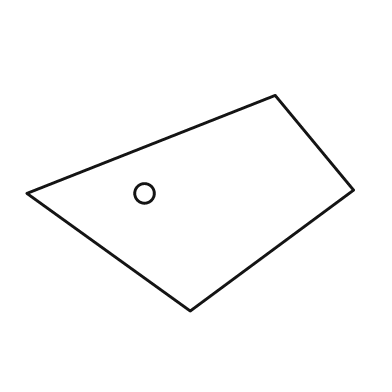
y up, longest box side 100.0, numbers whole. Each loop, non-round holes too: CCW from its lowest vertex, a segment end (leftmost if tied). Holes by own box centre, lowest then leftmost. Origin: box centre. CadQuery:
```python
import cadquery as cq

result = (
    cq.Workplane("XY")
    .moveTo(0.0, -33.0)
    .lineTo(50.0, 4.0)
    .lineTo(26.0, 33.0)
    .lineTo(-50.0, 3.0)
    .close()
    .moveTo(-14.0, 3.0)
    .circle(3.0)
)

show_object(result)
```